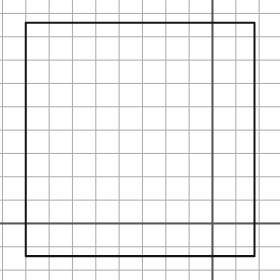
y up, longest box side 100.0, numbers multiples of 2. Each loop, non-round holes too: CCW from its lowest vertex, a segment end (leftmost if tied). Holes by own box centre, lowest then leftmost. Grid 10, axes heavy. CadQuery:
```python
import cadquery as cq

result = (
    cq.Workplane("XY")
    .moveTo(-80.0, -14.0)
    .lineTo(18.0, -14.0)
    .lineTo(18.0, 86.0)
    .lineTo(-80.0, 86.0)
    .close()
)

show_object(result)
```